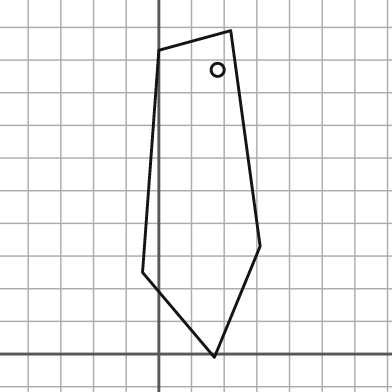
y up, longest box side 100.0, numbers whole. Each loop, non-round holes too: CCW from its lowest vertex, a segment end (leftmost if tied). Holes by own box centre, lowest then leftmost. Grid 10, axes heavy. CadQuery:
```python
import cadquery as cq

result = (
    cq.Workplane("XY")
    .moveTo(17.0, -1.0)
    .lineTo(31.0, 33.0)
    .lineTo(22.0, 99.0)
    .lineTo(0.0, 93.0)
    .lineTo(-5.0, 25.0)
    .close()
    .moveTo(18.0, 87.0)
    .circle(2.0)
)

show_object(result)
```